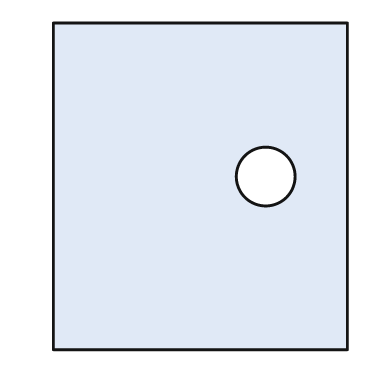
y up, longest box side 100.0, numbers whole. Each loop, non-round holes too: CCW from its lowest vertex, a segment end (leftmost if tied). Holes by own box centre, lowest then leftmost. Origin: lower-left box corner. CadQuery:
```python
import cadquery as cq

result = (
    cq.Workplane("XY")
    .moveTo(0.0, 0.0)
    .lineTo(90.0, 0.0)
    .lineTo(90.0, 100.0)
    .lineTo(0.0, 100.0)
    .close()
    .moveTo(65.0, 53.0)
    .circle(9.0)
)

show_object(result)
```